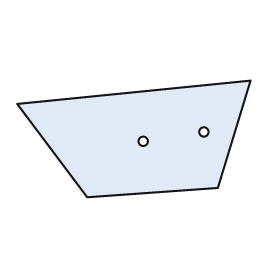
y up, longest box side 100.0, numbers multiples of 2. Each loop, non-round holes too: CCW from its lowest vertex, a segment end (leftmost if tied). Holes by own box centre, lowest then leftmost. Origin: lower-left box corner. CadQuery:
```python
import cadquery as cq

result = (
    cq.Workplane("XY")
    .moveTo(30.0, 0.0)
    .lineTo(86.0, 4.0)
    .lineTo(100.0, 50.0)
    .lineTo(0.0, 40.0)
    .close()
    .moveTo(54.0, 24.0)
    .circle(2.0)
    .moveTo(80.0, 28.0)
    .circle(2.0)
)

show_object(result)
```